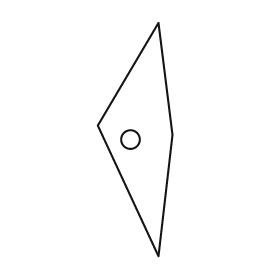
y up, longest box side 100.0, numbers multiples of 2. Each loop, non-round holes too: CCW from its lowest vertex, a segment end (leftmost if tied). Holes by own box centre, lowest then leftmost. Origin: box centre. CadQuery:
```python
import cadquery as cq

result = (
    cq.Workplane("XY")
    .moveTo(10.0, -50.0)
    .lineTo(16.0, 2.0)
    .lineTo(10.0, 50.0)
    .lineTo(-16.0, 6.0)
    .close()
    .moveTo(-2.0, 0.0)
    .circle(4.0)
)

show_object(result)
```